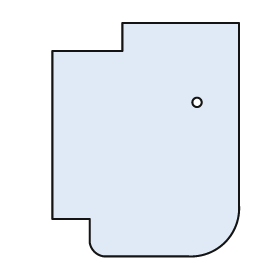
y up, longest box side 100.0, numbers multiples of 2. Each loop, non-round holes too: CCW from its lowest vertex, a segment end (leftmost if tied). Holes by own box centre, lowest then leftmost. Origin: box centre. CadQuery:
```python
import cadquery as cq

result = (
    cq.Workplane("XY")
    .moveTo(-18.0, -50.0)
    .lineTo(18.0, -50.0)
    .threePointArc((34.0, -44.0), (40.0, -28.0))
    .lineTo(40.0, 50.0)
    .lineTo(-10.0, 50.0)
    .lineTo(-10.0, 38.0)
    .lineTo(-40.0, 38.0)
    .lineTo(-40.0, -34.0)
    .lineTo(-24.0, -34.0)
    .lineTo(-24.0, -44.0)
    .threePointArc((-22.0, -48.0), (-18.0, -50.0))
    .close()
    .moveTo(22.0, 16.0)
    .circle(2.0)
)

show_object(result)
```